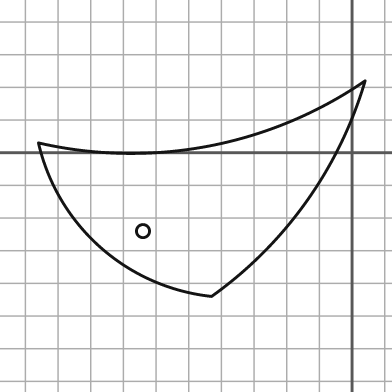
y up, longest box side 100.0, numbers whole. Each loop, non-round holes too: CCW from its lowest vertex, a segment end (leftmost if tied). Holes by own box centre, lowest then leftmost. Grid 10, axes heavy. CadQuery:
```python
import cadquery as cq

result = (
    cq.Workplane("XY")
    .moveTo(-43.0, -44.0)
    .threePointArc((-14.0, -15.0), (4.0, 22.0))
    .threePointArc((-44.0, 2.0), (-96.0, 3.0))
    .threePointArc((-77.0, -29.0), (-43.0, -44.0))
    .close()
    .moveTo(-64.0, -24.0)
    .circle(2.0)
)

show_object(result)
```